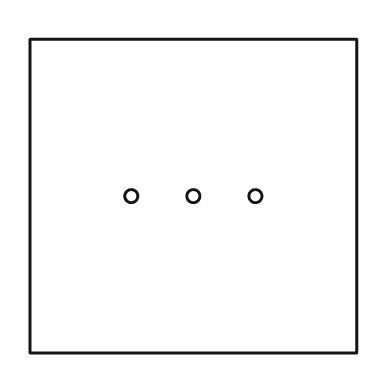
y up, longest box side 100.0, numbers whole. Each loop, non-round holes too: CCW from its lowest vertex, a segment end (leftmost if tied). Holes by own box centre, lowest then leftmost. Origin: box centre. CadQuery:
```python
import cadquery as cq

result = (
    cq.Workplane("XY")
    .moveTo(-50.0, -48.0)
    .lineTo(50.0, -48.0)
    .lineTo(50.0, 48.0)
    .lineTo(-50.0, 48.0)
    .close()
    .moveTo(-19.0, 0.0)
    .circle(2.0)
    .moveTo(0.0, 0.0)
    .circle(2.0)
    .moveTo(19.0, 0.0)
    .circle(2.0)
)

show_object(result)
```